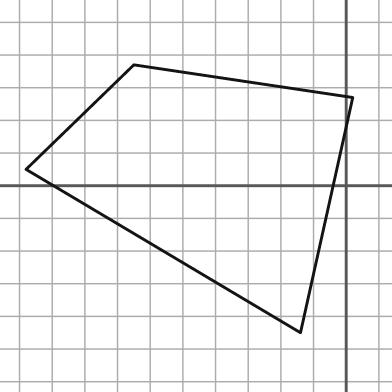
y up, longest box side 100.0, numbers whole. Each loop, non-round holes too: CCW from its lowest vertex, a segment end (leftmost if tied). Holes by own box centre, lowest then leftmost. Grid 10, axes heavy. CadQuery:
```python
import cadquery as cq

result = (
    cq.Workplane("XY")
    .moveTo(-14.0, -45.0)
    .lineTo(2.0, 27.0)
    .lineTo(-65.0, 37.0)
    .lineTo(-98.0, 5.0)
    .close()
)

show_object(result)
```